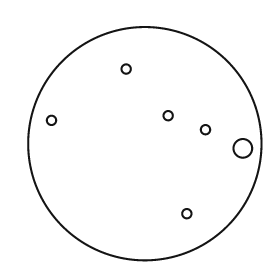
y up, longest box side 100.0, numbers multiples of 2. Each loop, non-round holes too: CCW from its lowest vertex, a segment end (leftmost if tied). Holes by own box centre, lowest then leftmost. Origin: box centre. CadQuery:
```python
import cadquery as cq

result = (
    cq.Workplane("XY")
    .moveTo(0.0, 0.0)
    .circle(50.0)
    .moveTo(18.0, -30.0)
    .circle(2.0)
    .moveTo(42.0, -2.0)
    .circle(4.0)
    .moveTo(26.0, 6.0)
    .circle(2.0)
    .moveTo(-40.0, 10.0)
    .circle(2.0)
    .moveTo(10.0, 12.0)
    .circle(2.0)
    .moveTo(-8.0, 32.0)
    .circle(2.0)
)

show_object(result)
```